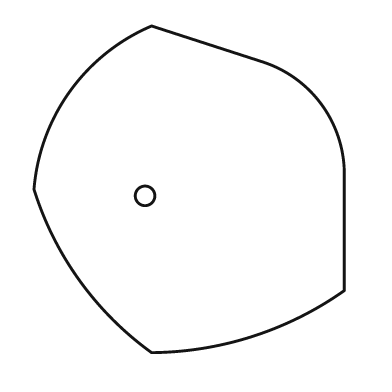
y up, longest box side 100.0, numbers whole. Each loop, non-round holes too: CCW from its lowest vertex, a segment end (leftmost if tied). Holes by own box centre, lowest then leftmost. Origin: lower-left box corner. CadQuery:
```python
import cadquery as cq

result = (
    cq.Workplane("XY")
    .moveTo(36.0, 0.0)
    .threePointArc((67.0, 5.0), (95.0, 19.0))
    .lineTo(95.0, 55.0)
    .threePointArc((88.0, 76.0), (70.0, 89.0))
    .lineTo(36.0, 100.0)
    .threePointArc((11.0, 80.0), (0.0, 50.0))
    .threePointArc((14.0, 22.0), (36.0, 0.0))
    .close()
    .moveTo(34.0, 48.0)
    .circle(3.0)
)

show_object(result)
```